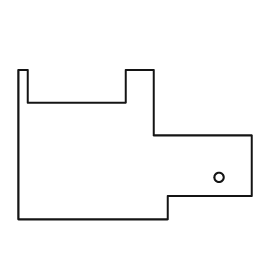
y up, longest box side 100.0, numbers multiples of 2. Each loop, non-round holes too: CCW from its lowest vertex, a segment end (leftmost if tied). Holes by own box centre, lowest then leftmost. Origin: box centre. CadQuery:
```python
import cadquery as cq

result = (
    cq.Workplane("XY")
    .moveTo(-50.0, -32.0)
    .lineTo(14.0, -32.0)
    .lineTo(14.0, -22.0)
    .lineTo(50.0, -22.0)
    .lineTo(50.0, 4.0)
    .lineTo(8.0, 4.0)
    .lineTo(8.0, 32.0)
    .lineTo(-4.0, 32.0)
    .lineTo(-4.0, 18.0)
    .lineTo(-46.0, 18.0)
    .lineTo(-46.0, 32.0)
    .lineTo(-50.0, 32.0)
    .close()
    .moveTo(36.0, -14.0)
    .circle(2.0)
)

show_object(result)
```